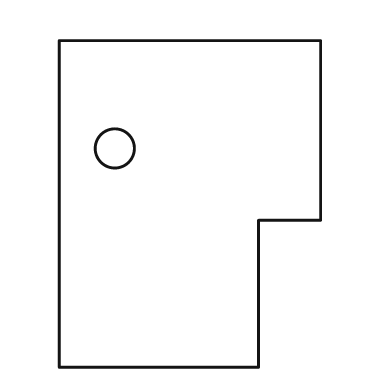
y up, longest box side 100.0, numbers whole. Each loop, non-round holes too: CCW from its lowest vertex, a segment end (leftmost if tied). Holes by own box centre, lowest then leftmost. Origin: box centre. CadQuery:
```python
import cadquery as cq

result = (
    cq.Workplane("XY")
    .moveTo(-40.0, -50.0)
    .lineTo(21.0, -50.0)
    .lineTo(21.0, -5.0)
    .lineTo(40.0, -5.0)
    .lineTo(40.0, 50.0)
    .lineTo(-40.0, 50.0)
    .close()
    .moveTo(-23.0, 17.0)
    .circle(6.0)
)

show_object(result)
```